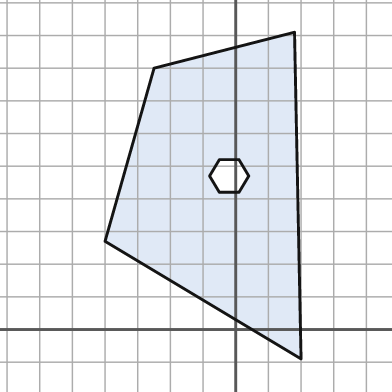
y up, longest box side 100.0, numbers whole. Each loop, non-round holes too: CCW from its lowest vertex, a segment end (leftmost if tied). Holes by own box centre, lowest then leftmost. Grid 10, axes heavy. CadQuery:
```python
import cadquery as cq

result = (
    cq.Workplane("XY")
    .moveTo(20.0, -9.0)
    .lineTo(18.0, 91.0)
    .lineTo(-25.0, 80.0)
    .lineTo(-40.0, 27.0)
    .close()
    .moveTo(-5.0, 42.0)
    .lineTo(1.0, 42.0)
    .lineTo(4.0, 47.0)
    .lineTo(1.0, 52.0)
    .lineTo(-5.0, 52.0)
    .lineTo(-8.0, 47.0)
    .close()
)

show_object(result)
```